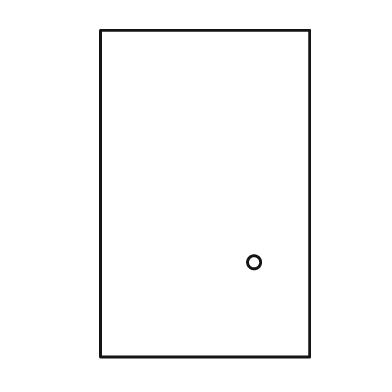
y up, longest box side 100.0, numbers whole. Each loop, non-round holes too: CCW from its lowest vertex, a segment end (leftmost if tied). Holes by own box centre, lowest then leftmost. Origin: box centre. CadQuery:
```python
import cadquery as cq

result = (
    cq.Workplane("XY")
    .moveTo(-32.0, -50.0)
    .lineTo(32.0, -50.0)
    .lineTo(32.0, 50.0)
    .lineTo(-32.0, 50.0)
    .close()
    .moveTo(15.0, -21.0)
    .circle(2.0)
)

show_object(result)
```